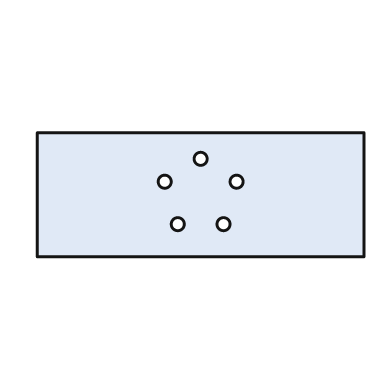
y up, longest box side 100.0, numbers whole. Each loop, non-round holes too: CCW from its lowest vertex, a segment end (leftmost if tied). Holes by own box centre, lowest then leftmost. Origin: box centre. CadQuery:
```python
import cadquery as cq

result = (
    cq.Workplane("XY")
    .moveTo(-50.0, -19.0)
    .lineTo(50.0, -19.0)
    .lineTo(50.0, 19.0)
    .lineTo(-50.0, 19.0)
    .close()
    .moveTo(-7.0, -9.0)
    .circle(2.0)
    .moveTo(7.0, -9.0)
    .circle(2.0)
    .moveTo(-11.0, 4.0)
    .circle(2.0)
    .moveTo(11.0, 4.0)
    .circle(2.0)
    .moveTo(0.0, 11.0)
    .circle(2.0)
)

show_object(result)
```